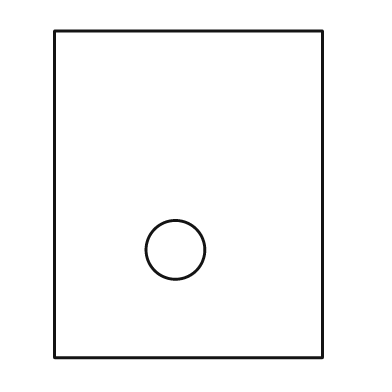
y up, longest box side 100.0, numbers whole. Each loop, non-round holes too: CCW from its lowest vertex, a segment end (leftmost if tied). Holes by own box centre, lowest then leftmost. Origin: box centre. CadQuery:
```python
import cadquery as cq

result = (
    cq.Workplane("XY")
    .moveTo(-41.0, -50.0)
    .lineTo(41.0, -50.0)
    .lineTo(41.0, 50.0)
    .lineTo(-41.0, 50.0)
    .close()
    .moveTo(-4.0, -17.0)
    .circle(9.0)
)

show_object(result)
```